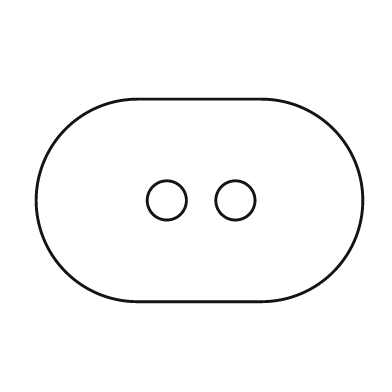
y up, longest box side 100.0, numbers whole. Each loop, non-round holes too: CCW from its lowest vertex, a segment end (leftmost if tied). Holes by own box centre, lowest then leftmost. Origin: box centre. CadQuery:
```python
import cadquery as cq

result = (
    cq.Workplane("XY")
    .moveTo(-19.0, -31.0)
    .lineTo(19.0, -31.0)
    .threePointArc((50.0, 0.0), (19.0, 31.0))
    .lineTo(-19.0, 31.0)
    .threePointArc((-50.0, 0.0), (-19.0, -31.0))
    .close()
    .moveTo(-10.0, 0.0)
    .circle(6.0)
    .moveTo(11.0, 0.0)
    .circle(6.0)
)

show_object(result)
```